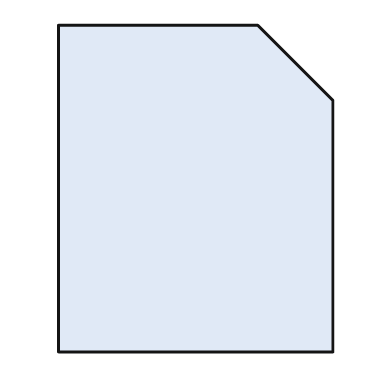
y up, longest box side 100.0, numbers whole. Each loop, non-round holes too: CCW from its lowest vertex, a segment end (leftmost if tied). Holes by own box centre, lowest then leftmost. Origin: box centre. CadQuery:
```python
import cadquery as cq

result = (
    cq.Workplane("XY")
    .moveTo(-42.0, -50.0)
    .lineTo(42.0, -50.0)
    .lineTo(42.0, 27.0)
    .lineTo(19.0, 50.0)
    .lineTo(-42.0, 50.0)
    .close()
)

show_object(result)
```